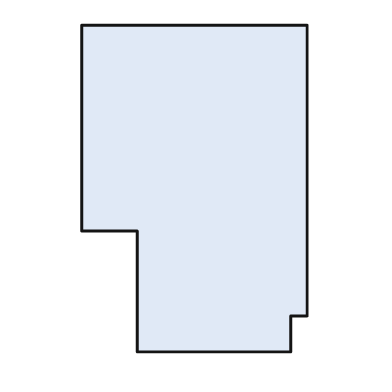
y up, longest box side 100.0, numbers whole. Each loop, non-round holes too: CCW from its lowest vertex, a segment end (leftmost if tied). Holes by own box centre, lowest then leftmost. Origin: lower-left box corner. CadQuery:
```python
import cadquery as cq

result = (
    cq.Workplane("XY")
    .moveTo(17.0, 0.0)
    .lineTo(64.0, 0.0)
    .lineTo(64.0, 11.0)
    .lineTo(69.0, 11.0)
    .lineTo(69.0, 100.0)
    .lineTo(0.0, 100.0)
    .lineTo(0.0, 37.0)
    .lineTo(17.0, 37.0)
    .close()
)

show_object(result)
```